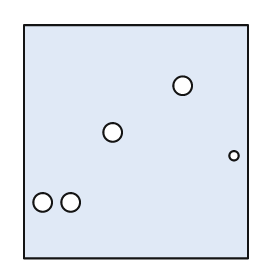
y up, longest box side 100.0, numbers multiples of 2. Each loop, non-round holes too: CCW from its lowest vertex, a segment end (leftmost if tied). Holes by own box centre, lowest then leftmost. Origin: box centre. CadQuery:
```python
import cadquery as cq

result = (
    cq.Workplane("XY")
    .moveTo(-48.0, -50.0)
    .lineTo(48.0, -50.0)
    .lineTo(48.0, 50.0)
    .lineTo(-48.0, 50.0)
    .close()
    .moveTo(-40.0, -26.0)
    .circle(4.0)
    .moveTo(-28.0, -26.0)
    .circle(4.0)
    .moveTo(42.0, -6.0)
    .circle(2.0)
    .moveTo(-10.0, 4.0)
    .circle(4.0)
    .moveTo(20.0, 24.0)
    .circle(4.0)
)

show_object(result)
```